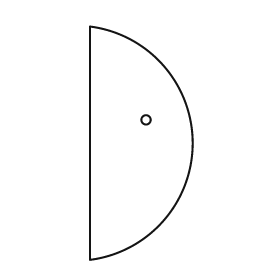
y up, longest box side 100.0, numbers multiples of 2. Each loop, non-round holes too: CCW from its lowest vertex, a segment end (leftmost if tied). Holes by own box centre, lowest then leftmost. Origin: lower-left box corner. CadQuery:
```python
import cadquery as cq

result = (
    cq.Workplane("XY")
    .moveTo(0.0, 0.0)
    .threePointArc((44.0, 50.0), (0.0, 100.0))
    .close()
    .moveTo(24.0, 60.0)
    .circle(2.0)
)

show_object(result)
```